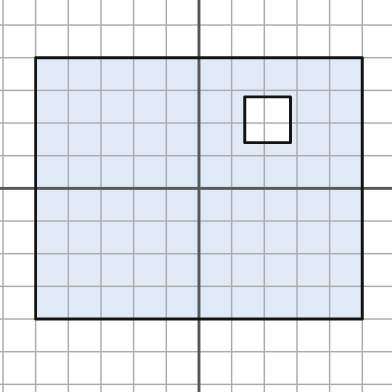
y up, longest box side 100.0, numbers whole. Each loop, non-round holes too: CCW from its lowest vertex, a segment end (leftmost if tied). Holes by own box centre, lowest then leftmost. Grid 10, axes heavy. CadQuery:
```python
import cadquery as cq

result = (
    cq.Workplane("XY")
    .moveTo(-50.0, -40.0)
    .lineTo(50.0, -40.0)
    .lineTo(50.0, 40.0)
    .lineTo(-50.0, 40.0)
    .close()
    .moveTo(14.0, 14.0)
    .lineTo(28.0, 14.0)
    .lineTo(28.0, 28.0)
    .lineTo(14.0, 28.0)
    .close()
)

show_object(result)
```